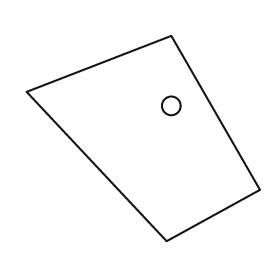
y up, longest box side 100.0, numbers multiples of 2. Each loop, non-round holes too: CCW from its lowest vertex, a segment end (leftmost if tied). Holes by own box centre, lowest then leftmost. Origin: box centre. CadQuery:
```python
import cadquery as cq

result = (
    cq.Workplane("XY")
    .moveTo(10.0, -44.0)
    .lineTo(50.0, -22.0)
    .lineTo(12.0, 44.0)
    .lineTo(-50.0, 20.0)
    .close()
    .moveTo(12.0, 14.0)
    .circle(4.0)
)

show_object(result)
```